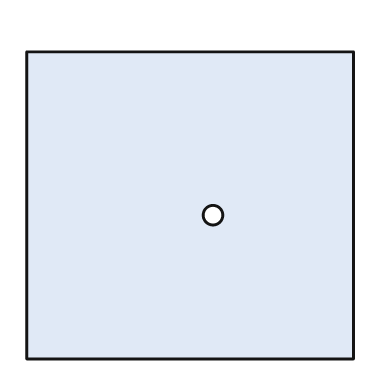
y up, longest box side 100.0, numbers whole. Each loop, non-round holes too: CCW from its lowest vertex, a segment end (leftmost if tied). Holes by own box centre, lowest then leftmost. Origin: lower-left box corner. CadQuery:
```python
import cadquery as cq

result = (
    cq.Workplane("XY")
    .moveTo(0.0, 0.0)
    .lineTo(100.0, 0.0)
    .lineTo(100.0, 94.0)
    .lineTo(0.0, 94.0)
    .close()
    .moveTo(57.0, 44.0)
    .circle(3.0)
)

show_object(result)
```